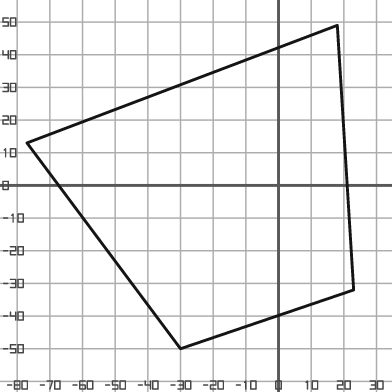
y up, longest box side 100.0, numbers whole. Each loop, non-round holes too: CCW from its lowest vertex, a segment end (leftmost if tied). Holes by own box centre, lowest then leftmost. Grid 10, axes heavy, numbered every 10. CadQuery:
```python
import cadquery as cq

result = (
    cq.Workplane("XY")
    .moveTo(-30.0, -50.0)
    .lineTo(23.0, -32.0)
    .lineTo(18.0, 49.0)
    .lineTo(-77.0, 13.0)
    .close()
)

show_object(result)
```